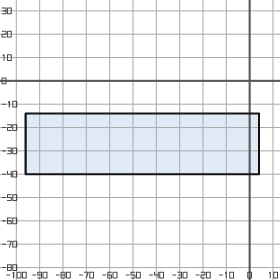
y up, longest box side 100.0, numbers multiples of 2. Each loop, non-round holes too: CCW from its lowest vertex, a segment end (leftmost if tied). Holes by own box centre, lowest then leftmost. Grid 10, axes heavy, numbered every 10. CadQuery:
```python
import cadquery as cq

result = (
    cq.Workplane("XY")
    .moveTo(-96.0, -40.0)
    .lineTo(4.0, -40.0)
    .lineTo(4.0, -14.0)
    .lineTo(-96.0, -14.0)
    .close()
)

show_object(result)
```